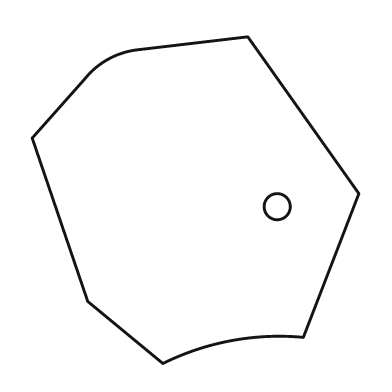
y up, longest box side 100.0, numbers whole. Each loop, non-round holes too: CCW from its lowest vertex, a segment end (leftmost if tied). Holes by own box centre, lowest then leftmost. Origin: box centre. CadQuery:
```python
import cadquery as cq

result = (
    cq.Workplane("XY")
    .moveTo(-10.0, -50.0)
    .threePointArc((11.0, -43.0), (33.0, -42.0))
    .lineTo(50.0, 2.0)
    .lineTo(16.0, 50.0)
    .lineTo(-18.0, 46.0)
    .threePointArc((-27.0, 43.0), (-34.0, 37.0))
    .lineTo(-50.0, 19.0)
    .lineTo(-33.0, -31.0)
    .close()
    .moveTo(25.0, -2.0)
    .circle(4.0)
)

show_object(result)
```